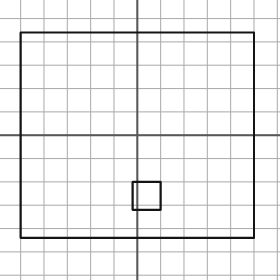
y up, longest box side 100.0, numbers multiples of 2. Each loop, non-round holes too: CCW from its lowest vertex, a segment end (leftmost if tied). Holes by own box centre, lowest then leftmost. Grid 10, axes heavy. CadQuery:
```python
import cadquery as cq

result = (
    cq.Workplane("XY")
    .moveTo(-50.0, -44.0)
    .lineTo(50.0, -44.0)
    .lineTo(50.0, 44.0)
    .lineTo(-50.0, 44.0)
    .close()
    .moveTo(-2.0, -32.0)
    .lineTo(10.0, -32.0)
    .lineTo(10.0, -20.0)
    .lineTo(-2.0, -20.0)
    .close()
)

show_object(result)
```